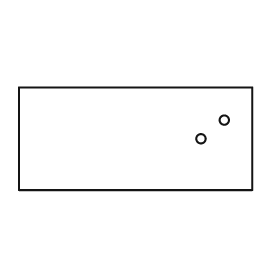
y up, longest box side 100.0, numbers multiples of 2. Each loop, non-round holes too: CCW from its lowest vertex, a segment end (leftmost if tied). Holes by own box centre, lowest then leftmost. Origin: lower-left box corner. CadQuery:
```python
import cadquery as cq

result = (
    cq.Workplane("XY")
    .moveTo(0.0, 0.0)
    .lineTo(100.0, 0.0)
    .lineTo(100.0, 44.0)
    .lineTo(0.0, 44.0)
    .close()
    .moveTo(78.0, 22.0)
    .circle(2.0)
    .moveTo(88.0, 30.0)
    .circle(2.0)
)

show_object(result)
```